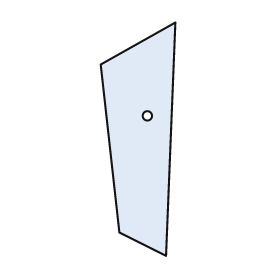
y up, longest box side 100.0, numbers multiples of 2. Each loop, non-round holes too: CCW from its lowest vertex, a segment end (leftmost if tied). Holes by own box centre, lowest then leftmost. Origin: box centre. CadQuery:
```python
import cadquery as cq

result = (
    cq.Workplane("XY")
    .moveTo(12.0, -50.0)
    .lineTo(16.0, 50.0)
    .lineTo(-16.0, 32.0)
    .lineTo(-8.0, -40.0)
    .close()
    .moveTo(4.0, 10.0)
    .circle(2.0)
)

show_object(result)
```